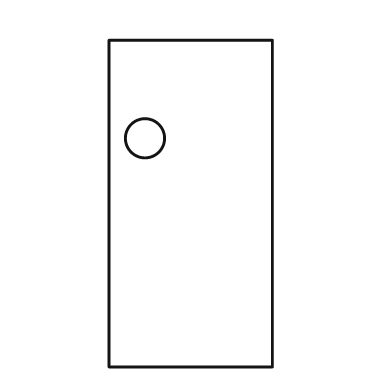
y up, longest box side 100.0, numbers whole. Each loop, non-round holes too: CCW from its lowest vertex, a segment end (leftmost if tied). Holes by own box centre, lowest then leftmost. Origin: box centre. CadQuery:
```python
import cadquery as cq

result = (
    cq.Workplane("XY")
    .moveTo(-25.0, -50.0)
    .lineTo(25.0, -50.0)
    .lineTo(25.0, 50.0)
    .lineTo(-25.0, 50.0)
    .close()
    .moveTo(-14.0, 20.0)
    .circle(6.0)
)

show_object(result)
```